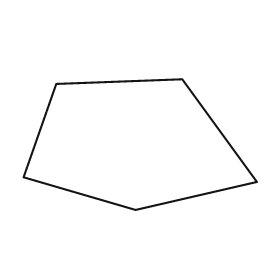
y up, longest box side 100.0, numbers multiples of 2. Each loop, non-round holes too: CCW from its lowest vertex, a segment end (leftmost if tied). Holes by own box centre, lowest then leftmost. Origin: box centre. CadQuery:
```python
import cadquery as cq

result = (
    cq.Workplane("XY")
    .moveTo(-2.0, -28.0)
    .lineTo(50.0, -16.0)
    .lineTo(18.0, 28.0)
    .lineTo(-36.0, 26.0)
    .lineTo(-50.0, -14.0)
    .close()
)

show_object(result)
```